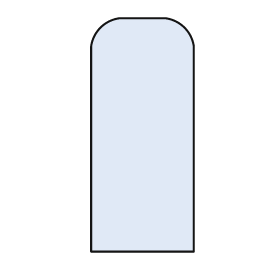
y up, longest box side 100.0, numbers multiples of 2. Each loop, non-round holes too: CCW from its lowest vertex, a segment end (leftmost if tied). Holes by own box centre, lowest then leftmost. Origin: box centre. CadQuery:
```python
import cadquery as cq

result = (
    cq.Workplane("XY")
    .moveTo(-22.0, -50.0)
    .lineTo(22.0, -50.0)
    .lineTo(22.0, 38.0)
    .threePointArc((18.0, 46.0), (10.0, 50.0))
    .lineTo(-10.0, 50.0)
    .threePointArc((-18.0, 46.0), (-22.0, 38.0))
    .close()
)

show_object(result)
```